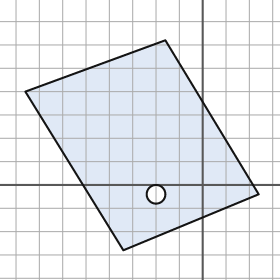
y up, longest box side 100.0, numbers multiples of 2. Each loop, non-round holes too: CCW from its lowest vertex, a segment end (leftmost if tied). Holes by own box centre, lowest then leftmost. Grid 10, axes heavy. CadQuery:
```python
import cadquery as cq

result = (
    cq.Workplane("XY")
    .moveTo(-34.0, -28.0)
    .lineTo(24.0, -4.0)
    .lineTo(-16.0, 62.0)
    .lineTo(-76.0, 40.0)
    .close()
    .moveTo(-20.0, -4.0)
    .circle(4.0)
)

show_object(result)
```